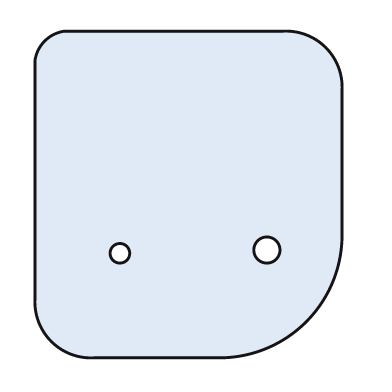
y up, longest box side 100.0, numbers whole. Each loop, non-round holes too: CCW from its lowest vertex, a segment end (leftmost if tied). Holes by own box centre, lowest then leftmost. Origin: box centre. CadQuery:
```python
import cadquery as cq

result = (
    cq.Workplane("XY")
    .moveTo(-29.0, -50.0)
    .lineTo(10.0, -50.0)
    .threePointArc((36.0, -39.0), (47.0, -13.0))
    .lineTo(47.0, 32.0)
    .threePointArc((42.0, 45.0), (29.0, 50.0))
    .lineTo(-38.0, 50.0)
    .threePointArc((-44.0, 47.0), (-47.0, 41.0))
    .lineTo(-47.0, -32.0)
    .threePointArc((-42.0, -45.0), (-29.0, -50.0))
    .close()
    .moveTo(-21.0, -18.0)
    .circle(3.0)
    .moveTo(24.0, -17.0)
    .circle(4.0)
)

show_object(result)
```